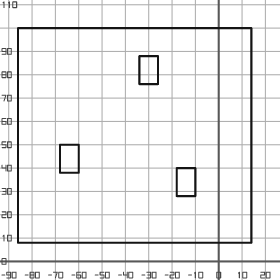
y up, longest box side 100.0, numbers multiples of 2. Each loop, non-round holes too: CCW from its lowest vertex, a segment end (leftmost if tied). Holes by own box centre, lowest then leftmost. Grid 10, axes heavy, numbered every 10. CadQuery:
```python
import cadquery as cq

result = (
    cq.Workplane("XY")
    .moveTo(-86.0, 8.0)
    .lineTo(14.0, 8.0)
    .lineTo(14.0, 100.0)
    .lineTo(-86.0, 100.0)
    .close()
    .moveTo(-18.0, 28.0)
    .lineTo(-10.0, 28.0)
    .lineTo(-10.0, 40.0)
    .lineTo(-18.0, 40.0)
    .close()
    .moveTo(-68.0, 38.0)
    .lineTo(-60.0, 38.0)
    .lineTo(-60.0, 50.0)
    .lineTo(-68.0, 50.0)
    .close()
    .moveTo(-34.0, 76.0)
    .lineTo(-26.0, 76.0)
    .lineTo(-26.0, 88.0)
    .lineTo(-34.0, 88.0)
    .close()
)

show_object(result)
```